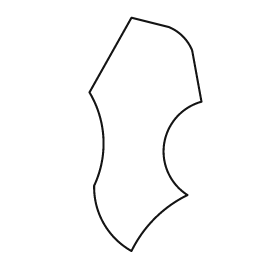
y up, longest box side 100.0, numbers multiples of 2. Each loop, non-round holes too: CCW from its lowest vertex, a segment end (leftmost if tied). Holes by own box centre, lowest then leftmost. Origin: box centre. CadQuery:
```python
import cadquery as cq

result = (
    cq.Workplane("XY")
    .moveTo(-6.0, -50.0)
    .threePointArc((4.0, -36.0), (18.0, -26.0))
    .threePointArc((8.0, -4.0), (24.0, 14.0))
    .lineTo(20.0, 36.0)
    .threePointArc((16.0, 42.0), (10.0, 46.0))
    .lineTo(-6.0, 50.0)
    .lineTo(-24.0, 18.0)
    .threePointArc((-18.0, -2.0), (-22.0, -22.0))
    .threePointArc((-18.0, -38.0), (-6.0, -50.0))
    .close()
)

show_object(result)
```